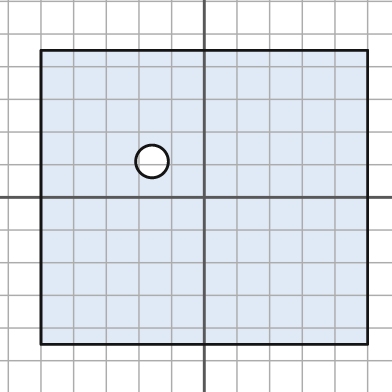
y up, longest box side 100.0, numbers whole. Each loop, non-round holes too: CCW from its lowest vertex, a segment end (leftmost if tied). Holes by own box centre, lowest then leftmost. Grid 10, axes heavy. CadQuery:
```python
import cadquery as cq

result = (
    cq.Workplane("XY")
    .moveTo(-50.0, -45.0)
    .lineTo(50.0, -45.0)
    .lineTo(50.0, 45.0)
    .lineTo(-50.0, 45.0)
    .close()
    .moveTo(-16.0, 11.0)
    .circle(5.0)
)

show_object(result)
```